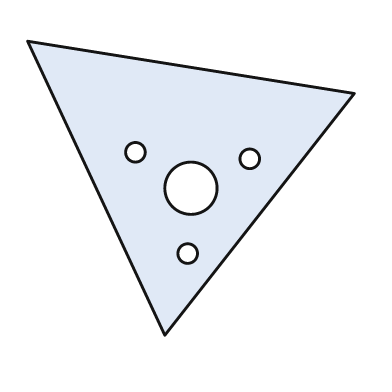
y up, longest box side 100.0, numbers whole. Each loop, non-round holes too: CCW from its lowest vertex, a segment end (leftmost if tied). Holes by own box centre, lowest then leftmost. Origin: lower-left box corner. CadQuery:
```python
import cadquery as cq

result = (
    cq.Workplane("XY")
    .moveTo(42.0, 0.0)
    .lineTo(100.0, 74.0)
    .lineTo(0.0, 90.0)
    .close()
    .moveTo(49.0, 25.0)
    .circle(3.0)
    .moveTo(50.0, 45.0)
    .circle(8.0)
    .moveTo(68.0, 54.0)
    .circle(3.0)
    .moveTo(33.0, 56.0)
    .circle(3.0)
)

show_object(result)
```